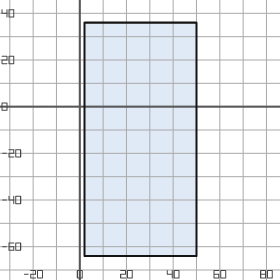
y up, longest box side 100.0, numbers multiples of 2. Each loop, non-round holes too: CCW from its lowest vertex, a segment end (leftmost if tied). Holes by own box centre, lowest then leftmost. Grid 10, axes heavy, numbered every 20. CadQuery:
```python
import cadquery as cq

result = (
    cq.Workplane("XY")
    .moveTo(2.0, -64.0)
    .lineTo(50.0, -64.0)
    .lineTo(50.0, 36.0)
    .lineTo(2.0, 36.0)
    .close()
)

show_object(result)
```